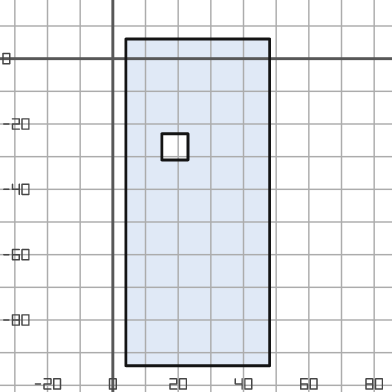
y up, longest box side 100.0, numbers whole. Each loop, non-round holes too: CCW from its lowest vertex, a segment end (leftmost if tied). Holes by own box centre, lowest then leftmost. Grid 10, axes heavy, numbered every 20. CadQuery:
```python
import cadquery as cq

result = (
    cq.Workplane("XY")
    .moveTo(4.0, -94.0)
    .lineTo(48.0, -94.0)
    .lineTo(48.0, 6.0)
    .lineTo(4.0, 6.0)
    .close()
    .moveTo(15.0, -31.0)
    .lineTo(23.0, -31.0)
    .lineTo(23.0, -23.0)
    .lineTo(15.0, -23.0)
    .close()
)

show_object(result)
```